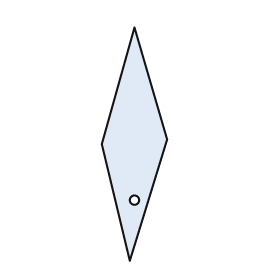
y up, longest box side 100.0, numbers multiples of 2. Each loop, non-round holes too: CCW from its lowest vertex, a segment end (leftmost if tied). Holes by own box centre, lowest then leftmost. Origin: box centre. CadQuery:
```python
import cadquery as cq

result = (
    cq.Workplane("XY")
    .moveTo(-2.0, -50.0)
    .lineTo(14.0, 2.0)
    .lineTo(0.0, 50.0)
    .lineTo(-14.0, 0.0)
    .close()
    .moveTo(0.0, -24.0)
    .circle(2.0)
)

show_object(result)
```